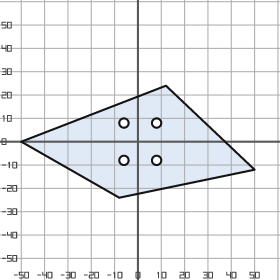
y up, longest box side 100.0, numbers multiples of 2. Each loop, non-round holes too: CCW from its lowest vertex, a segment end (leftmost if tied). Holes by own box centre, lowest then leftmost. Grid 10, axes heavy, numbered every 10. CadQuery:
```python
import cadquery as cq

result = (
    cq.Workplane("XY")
    .moveTo(-8.0, -24.0)
    .lineTo(50.0, -12.0)
    .lineTo(12.0, 24.0)
    .lineTo(-50.0, 0.0)
    .close()
    .moveTo(-6.0, -8.0)
    .circle(2.0)
    .moveTo(8.0, -8.0)
    .circle(2.0)
    .moveTo(-6.0, 8.0)
    .circle(2.0)
    .moveTo(8.0, 8.0)
    .circle(2.0)
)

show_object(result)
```